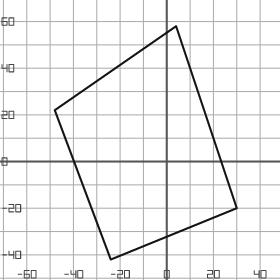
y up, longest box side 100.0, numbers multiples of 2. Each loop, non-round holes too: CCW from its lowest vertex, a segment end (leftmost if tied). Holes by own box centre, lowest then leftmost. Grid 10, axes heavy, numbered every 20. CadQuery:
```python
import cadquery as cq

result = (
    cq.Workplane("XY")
    .moveTo(-24.0, -42.0)
    .lineTo(30.0, -20.0)
    .lineTo(4.0, 58.0)
    .lineTo(-48.0, 22.0)
    .close()
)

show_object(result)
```